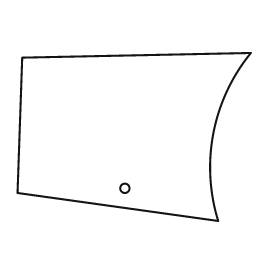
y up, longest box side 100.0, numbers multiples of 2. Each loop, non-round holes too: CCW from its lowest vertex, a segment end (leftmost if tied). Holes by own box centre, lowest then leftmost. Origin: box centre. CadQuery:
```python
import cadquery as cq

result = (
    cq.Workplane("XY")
    .moveTo(36.0, -36.0)
    .threePointArc((34.0, 2.0), (50.0, 36.0))
    .lineTo(-48.0, 34.0)
    .lineTo(-50.0, -24.0)
    .close()
    .moveTo(-4.0, -22.0)
    .circle(2.0)
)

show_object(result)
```